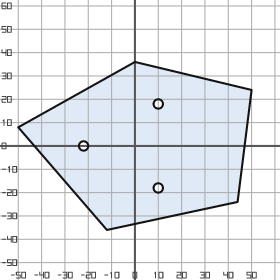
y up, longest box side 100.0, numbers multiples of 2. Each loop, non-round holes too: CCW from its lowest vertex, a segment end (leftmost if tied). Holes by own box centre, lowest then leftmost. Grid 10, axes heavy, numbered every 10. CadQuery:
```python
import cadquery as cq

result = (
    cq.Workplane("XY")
    .moveTo(-12.0, -36.0)
    .lineTo(44.0, -24.0)
    .lineTo(50.0, 24.0)
    .lineTo(0.0, 36.0)
    .lineTo(-50.0, 8.0)
    .close()
    .moveTo(10.0, -18.0)
    .circle(2.0)
    .moveTo(-22.0, 0.0)
    .circle(2.0)
    .moveTo(10.0, 18.0)
    .circle(2.0)
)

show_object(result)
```